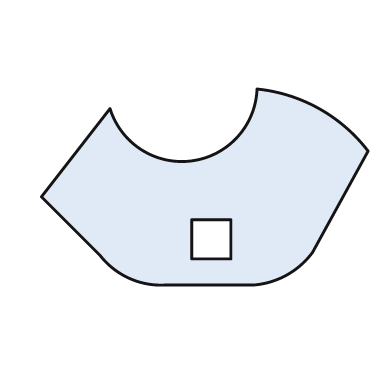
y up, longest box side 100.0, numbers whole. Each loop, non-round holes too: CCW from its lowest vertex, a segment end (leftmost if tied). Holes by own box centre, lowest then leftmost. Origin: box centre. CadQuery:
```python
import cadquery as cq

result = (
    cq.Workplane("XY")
    .moveTo(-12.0, -30.0)
    .lineTo(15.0, -30.0)
    .threePointArc((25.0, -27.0), (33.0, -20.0))
    .lineTo(50.0, 11.0)
    .threePointArc((35.0, 24.0), (16.0, 30.0))
    .threePointArc((-4.0, 8.0), (-29.0, 24.0))
    .lineTo(-50.0, -3.0)
    .lineTo(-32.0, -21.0)
    .threePointArc((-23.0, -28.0), (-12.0, -30.0))
    .close()
    .moveTo(-4.0, -22.0)
    .lineTo(8.0, -22.0)
    .lineTo(8.0, -10.0)
    .lineTo(-4.0, -10.0)
    .close()
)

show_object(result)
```